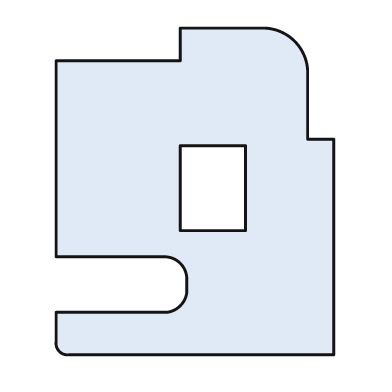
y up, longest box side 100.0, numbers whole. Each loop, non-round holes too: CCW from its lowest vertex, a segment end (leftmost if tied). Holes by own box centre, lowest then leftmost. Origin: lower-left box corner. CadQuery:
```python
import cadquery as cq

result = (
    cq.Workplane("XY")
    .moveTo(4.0, 0.0)
    .lineTo(85.0, 0.0)
    .lineTo(85.0, 66.0)
    .lineTo(77.0, 66.0)
    .lineTo(77.0, 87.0)
    .threePointArc((73.0, 96.0), (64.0, 100.0))
    .lineTo(38.0, 100.0)
    .lineTo(38.0, 90.0)
    .lineTo(0.0, 90.0)
    .lineTo(0.0, 30.0)
    .lineTo(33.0, 30.0)
    .threePointArc((38.0, 28.0), (40.0, 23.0))
    .lineTo(40.0, 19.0)
    .threePointArc((38.0, 15.0), (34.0, 13.0))
    .lineTo(0.0, 13.0)
    .lineTo(0.0, 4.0)
    .threePointArc((1.0, 1.0), (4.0, 0.0))
    .close()
    .moveTo(38.0, 38.0)
    .lineTo(58.0, 38.0)
    .lineTo(58.0, 64.0)
    .lineTo(38.0, 64.0)
    .close()
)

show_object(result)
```